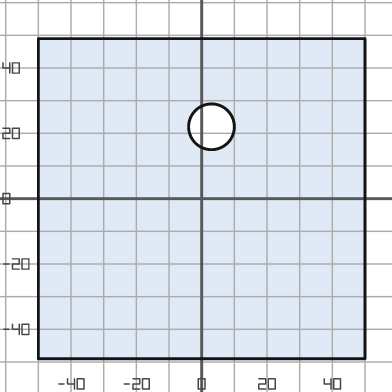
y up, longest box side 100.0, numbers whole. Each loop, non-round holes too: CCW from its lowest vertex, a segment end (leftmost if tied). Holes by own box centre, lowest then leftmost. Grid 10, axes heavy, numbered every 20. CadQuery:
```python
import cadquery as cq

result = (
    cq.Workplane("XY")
    .moveTo(-50.0, -49.0)
    .lineTo(50.0, -49.0)
    .lineTo(50.0, 49.0)
    .lineTo(-50.0, 49.0)
    .close()
    .moveTo(3.0, 22.0)
    .circle(7.0)
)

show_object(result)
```